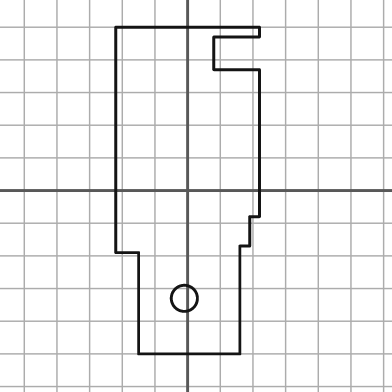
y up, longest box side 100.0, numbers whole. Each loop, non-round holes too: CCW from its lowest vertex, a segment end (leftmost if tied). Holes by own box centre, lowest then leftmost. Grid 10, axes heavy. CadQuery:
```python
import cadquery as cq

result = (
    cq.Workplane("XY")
    .moveTo(-15.0, -50.0)
    .lineTo(16.0, -50.0)
    .lineTo(16.0, -17.0)
    .lineTo(19.0, -17.0)
    .lineTo(19.0, -8.0)
    .lineTo(22.0, -8.0)
    .lineTo(22.0, 37.0)
    .lineTo(8.0, 37.0)
    .lineTo(8.0, 47.0)
    .lineTo(22.0, 47.0)
    .lineTo(22.0, 50.0)
    .lineTo(-22.0, 50.0)
    .lineTo(-22.0, -19.0)
    .lineTo(-15.0, -19.0)
    .close()
    .moveTo(-1.0, -33.0)
    .circle(4.0)
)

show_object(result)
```